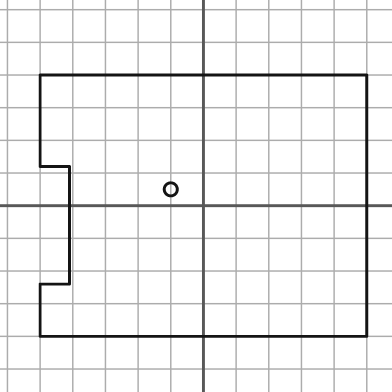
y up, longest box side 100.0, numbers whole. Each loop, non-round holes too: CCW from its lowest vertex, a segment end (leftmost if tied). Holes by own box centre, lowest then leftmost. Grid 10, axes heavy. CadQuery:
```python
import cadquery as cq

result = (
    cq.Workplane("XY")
    .moveTo(-50.0, -40.0)
    .lineTo(50.0, -40.0)
    .lineTo(50.0, 40.0)
    .lineTo(-50.0, 40.0)
    .lineTo(-50.0, 12.0)
    .lineTo(-41.0, 12.0)
    .lineTo(-41.0, -24.0)
    .lineTo(-50.0, -24.0)
    .close()
    .moveTo(-10.0, 5.0)
    .circle(2.0)
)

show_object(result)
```